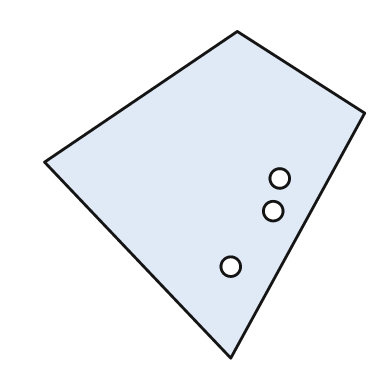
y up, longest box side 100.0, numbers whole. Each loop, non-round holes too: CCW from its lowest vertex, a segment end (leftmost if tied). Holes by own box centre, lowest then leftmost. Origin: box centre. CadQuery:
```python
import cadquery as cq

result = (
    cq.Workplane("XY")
    .moveTo(8.0, -50.0)
    .lineTo(49.0, 25.0)
    .lineTo(10.0, 50.0)
    .lineTo(-49.0, 10.0)
    .close()
    .moveTo(8.0, -22.0)
    .circle(3.0)
    .moveTo(21.0, -5.0)
    .circle(3.0)
    .moveTo(23.0, 5.0)
    .circle(3.0)
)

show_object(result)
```